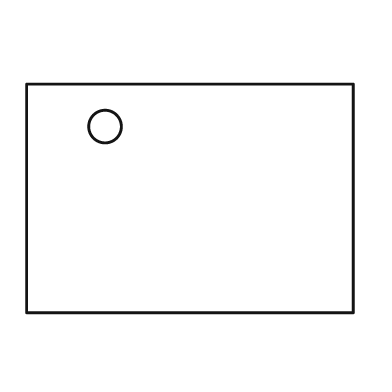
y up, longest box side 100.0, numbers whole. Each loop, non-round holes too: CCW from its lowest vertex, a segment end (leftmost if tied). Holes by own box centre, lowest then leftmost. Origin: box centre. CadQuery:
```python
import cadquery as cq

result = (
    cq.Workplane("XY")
    .moveTo(-50.0, -35.0)
    .lineTo(50.0, -35.0)
    .lineTo(50.0, 35.0)
    .lineTo(-50.0, 35.0)
    .close()
    .moveTo(-26.0, 22.0)
    .circle(5.0)
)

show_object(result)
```